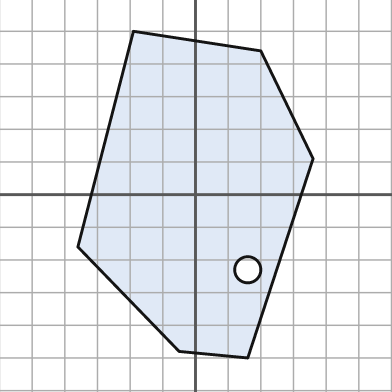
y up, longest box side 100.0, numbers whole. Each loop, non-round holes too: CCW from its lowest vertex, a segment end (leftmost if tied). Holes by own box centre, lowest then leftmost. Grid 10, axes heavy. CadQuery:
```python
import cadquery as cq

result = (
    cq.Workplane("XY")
    .moveTo(16.0, -50.0)
    .lineTo(36.0, 11.0)
    .lineTo(20.0, 44.0)
    .lineTo(-19.0, 50.0)
    .lineTo(-36.0, -16.0)
    .lineTo(-5.0, -48.0)
    .close()
    .moveTo(16.0, -23.0)
    .circle(4.0)
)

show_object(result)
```